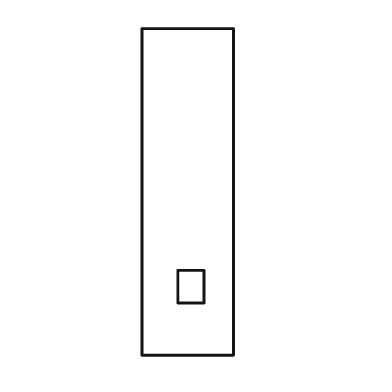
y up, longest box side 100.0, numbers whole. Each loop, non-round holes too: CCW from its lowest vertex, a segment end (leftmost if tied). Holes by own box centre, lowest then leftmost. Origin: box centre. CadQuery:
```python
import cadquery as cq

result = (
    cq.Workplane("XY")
    .moveTo(-14.0, -50.0)
    .lineTo(14.0, -50.0)
    .lineTo(14.0, 50.0)
    .lineTo(-14.0, 50.0)
    .close()
    .moveTo(-3.0, -34.0)
    .lineTo(5.0, -34.0)
    .lineTo(5.0, -24.0)
    .lineTo(-3.0, -24.0)
    .close()
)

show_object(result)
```